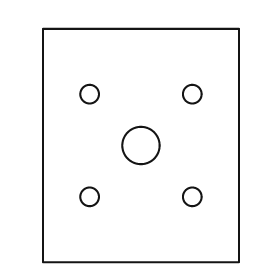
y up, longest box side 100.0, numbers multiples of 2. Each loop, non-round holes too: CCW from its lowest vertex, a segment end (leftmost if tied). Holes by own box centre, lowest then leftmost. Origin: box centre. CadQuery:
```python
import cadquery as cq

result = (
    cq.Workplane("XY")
    .moveTo(-42.0, -50.0)
    .lineTo(42.0, -50.0)
    .lineTo(42.0, 50.0)
    .lineTo(-42.0, 50.0)
    .close()
    .moveTo(-22.0, -22.0)
    .circle(4.0)
    .moveTo(22.0, -22.0)
    .circle(4.0)
    .moveTo(0.0, 0.0)
    .circle(8.0)
    .moveTo(-22.0, 22.0)
    .circle(4.0)
    .moveTo(22.0, 22.0)
    .circle(4.0)
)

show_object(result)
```